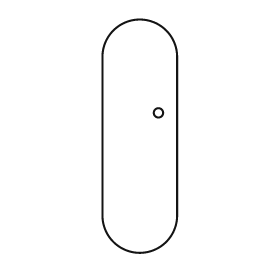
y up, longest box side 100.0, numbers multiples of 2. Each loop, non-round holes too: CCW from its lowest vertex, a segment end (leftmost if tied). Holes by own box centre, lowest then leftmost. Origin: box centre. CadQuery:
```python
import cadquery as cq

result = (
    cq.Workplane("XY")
    .moveTo(-16.0, -34.0)
    .threePointArc((0.0, -50.0), (16.0, -34.0))
    .lineTo(16.0, 34.0)
    .threePointArc((0.0, 50.0), (-16.0, 34.0))
    .close()
    .moveTo(8.0, 10.0)
    .circle(2.0)
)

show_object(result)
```